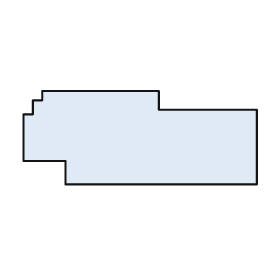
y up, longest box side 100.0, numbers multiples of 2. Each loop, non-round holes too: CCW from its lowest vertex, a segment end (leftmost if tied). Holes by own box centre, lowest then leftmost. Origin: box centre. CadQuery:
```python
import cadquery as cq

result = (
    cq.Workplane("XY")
    .moveTo(-32.0, -20.0)
    .lineTo(50.0, -20.0)
    .lineTo(50.0, 12.0)
    .lineTo(8.0, 12.0)
    .lineTo(8.0, 20.0)
    .lineTo(-42.0, 20.0)
    .lineTo(-42.0, 16.0)
    .lineTo(-46.0, 16.0)
    .lineTo(-46.0, 10.0)
    .lineTo(-50.0, 10.0)
    .lineTo(-50.0, -10.0)
    .lineTo(-32.0, -10.0)
    .close()
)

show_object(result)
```